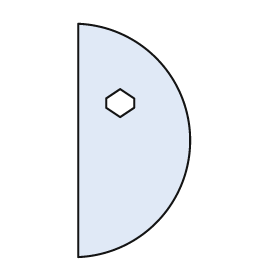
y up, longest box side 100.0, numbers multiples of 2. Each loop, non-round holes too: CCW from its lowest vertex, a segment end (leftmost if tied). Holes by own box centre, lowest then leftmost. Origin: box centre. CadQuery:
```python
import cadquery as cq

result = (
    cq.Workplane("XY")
    .moveTo(-24.0, -50.0)
    .threePointArc((24.0, 0.0), (-24.0, 50.0))
    .close()
    .moveTo(-6.0, 10.0)
    .lineTo(0.0, 14.0)
    .lineTo(0.0, 18.0)
    .lineTo(-6.0, 22.0)
    .lineTo(-12.0, 18.0)
    .lineTo(-12.0, 14.0)
    .close()
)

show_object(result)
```